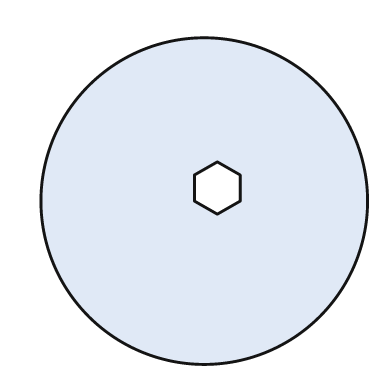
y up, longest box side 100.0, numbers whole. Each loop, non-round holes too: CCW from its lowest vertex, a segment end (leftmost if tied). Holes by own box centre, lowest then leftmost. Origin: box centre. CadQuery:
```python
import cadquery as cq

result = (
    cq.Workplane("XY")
    .moveTo(0.0, 0.0)
    .circle(50.0)
    .moveTo(4.0, -4.0)
    .lineTo(11.0, 0.0)
    .lineTo(11.0, 8.0)
    .lineTo(4.0, 12.0)
    .lineTo(-3.0, 8.0)
    .lineTo(-3.0, 0.0)
    .close()
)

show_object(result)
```